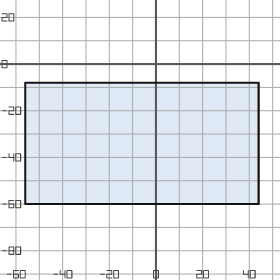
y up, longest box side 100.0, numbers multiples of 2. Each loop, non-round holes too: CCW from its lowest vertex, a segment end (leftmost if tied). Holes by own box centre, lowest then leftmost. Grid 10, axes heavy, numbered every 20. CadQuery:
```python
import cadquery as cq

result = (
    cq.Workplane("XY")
    .moveTo(-56.0, -60.0)
    .lineTo(44.0, -60.0)
    .lineTo(44.0, -8.0)
    .lineTo(-56.0, -8.0)
    .close()
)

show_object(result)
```